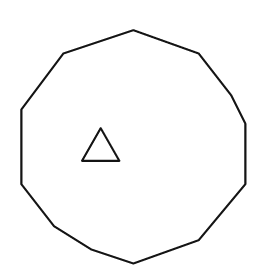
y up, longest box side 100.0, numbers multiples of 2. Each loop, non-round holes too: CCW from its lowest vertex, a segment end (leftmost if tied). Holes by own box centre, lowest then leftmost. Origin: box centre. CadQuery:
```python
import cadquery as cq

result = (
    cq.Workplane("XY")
    .moveTo(0.0, -50.0)
    .lineTo(28.0, -40.0)
    .lineTo(48.0, -16.0)
    .lineTo(48.0, 10.0)
    .lineTo(42.0, 22.0)
    .lineTo(28.0, 40.0)
    .lineTo(0.0, 50.0)
    .lineTo(-30.0, 40.0)
    .lineTo(-48.0, 16.0)
    .lineTo(-48.0, -16.0)
    .lineTo(-34.0, -34.0)
    .lineTo(-18.0, -44.0)
    .close()
    .moveTo(-22.0, -6.0)
    .lineTo(-6.0, -6.0)
    .lineTo(-14.0, 8.0)
    .close()
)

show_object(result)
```